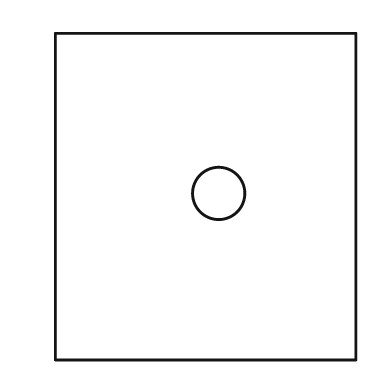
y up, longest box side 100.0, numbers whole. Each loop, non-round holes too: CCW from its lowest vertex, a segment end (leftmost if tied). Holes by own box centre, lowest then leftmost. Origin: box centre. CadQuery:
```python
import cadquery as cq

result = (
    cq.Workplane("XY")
    .moveTo(-46.0, -50.0)
    .lineTo(46.0, -50.0)
    .lineTo(46.0, 50.0)
    .lineTo(-46.0, 50.0)
    .close()
    .moveTo(4.0, 1.0)
    .circle(8.0)
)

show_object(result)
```